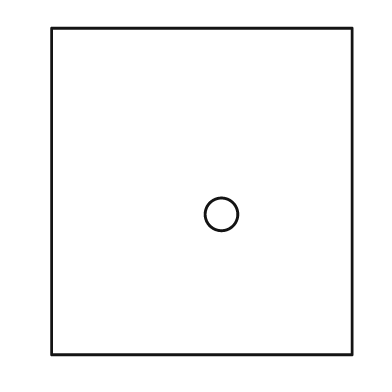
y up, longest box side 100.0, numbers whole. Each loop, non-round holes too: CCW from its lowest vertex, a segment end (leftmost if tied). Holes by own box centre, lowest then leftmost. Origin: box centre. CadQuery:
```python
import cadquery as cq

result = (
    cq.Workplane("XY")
    .moveTo(-46.0, -50.0)
    .lineTo(46.0, -50.0)
    .lineTo(46.0, 50.0)
    .lineTo(-46.0, 50.0)
    .close()
    .moveTo(6.0, -7.0)
    .circle(5.0)
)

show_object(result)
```